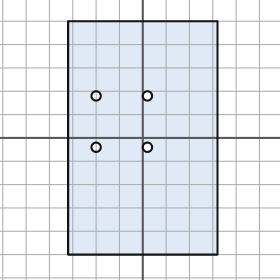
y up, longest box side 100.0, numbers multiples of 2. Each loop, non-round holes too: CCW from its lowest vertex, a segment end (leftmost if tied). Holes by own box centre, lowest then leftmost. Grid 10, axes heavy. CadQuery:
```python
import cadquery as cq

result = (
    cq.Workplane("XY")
    .moveTo(-32.0, -50.0)
    .lineTo(32.0, -50.0)
    .lineTo(32.0, 50.0)
    .lineTo(-32.0, 50.0)
    .close()
    .moveTo(-20.0, -4.0)
    .circle(2.0)
    .moveTo(2.0, -4.0)
    .circle(2.0)
    .moveTo(-20.0, 18.0)
    .circle(2.0)
    .moveTo(2.0, 18.0)
    .circle(2.0)
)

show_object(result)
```